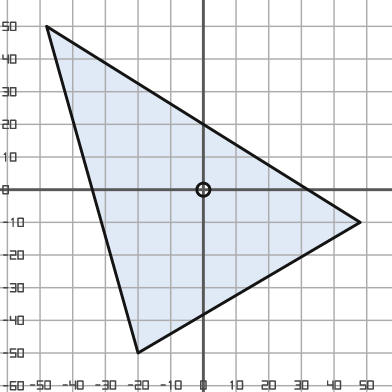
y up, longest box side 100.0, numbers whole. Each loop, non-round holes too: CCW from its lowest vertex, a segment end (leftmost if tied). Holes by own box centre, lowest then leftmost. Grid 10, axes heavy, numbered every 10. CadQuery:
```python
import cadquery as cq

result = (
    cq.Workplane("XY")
    .moveTo(-20.0, -50.0)
    .lineTo(48.0, -10.0)
    .lineTo(-48.0, 50.0)
    .close()
    .moveTo(0.0, 0.0)
    .circle(2.0)
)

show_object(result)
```